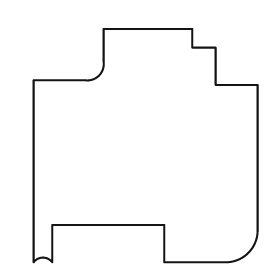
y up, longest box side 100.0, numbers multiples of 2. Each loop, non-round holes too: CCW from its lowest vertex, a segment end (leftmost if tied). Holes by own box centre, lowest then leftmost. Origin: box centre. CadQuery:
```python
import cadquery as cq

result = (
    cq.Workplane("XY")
    .moveTo(-48.0, -50.0)
    .threePointArc((-44.0, -48.0), (-40.0, -50.0))
    .lineTo(-40.0, -34.0)
    .lineTo(8.0, -34.0)
    .lineTo(8.0, -50.0)
    .lineTo(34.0, -50.0)
    .threePointArc((44.0, -46.0), (48.0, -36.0))
    .lineTo(48.0, 26.0)
    .lineTo(30.0, 26.0)
    .lineTo(30.0, 42.0)
    .lineTo(20.0, 42.0)
    .lineTo(20.0, 50.0)
    .lineTo(-18.0, 50.0)
    .lineTo(-18.0, 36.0)
    .threePointArc((-20.0, 30.0), (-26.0, 28.0))
    .lineTo(-48.0, 28.0)
    .close()
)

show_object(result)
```